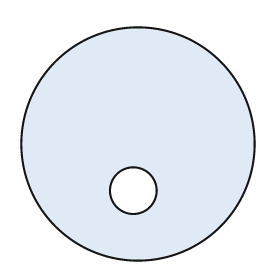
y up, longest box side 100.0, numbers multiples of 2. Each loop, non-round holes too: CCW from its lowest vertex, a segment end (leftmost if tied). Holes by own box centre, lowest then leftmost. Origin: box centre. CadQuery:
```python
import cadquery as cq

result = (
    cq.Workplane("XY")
    .moveTo(0.0, 0.0)
    .circle(50.0)
    .moveTo(-2.0, -20.0)
    .circle(10.0)
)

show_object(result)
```